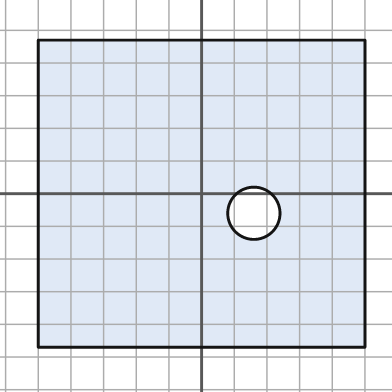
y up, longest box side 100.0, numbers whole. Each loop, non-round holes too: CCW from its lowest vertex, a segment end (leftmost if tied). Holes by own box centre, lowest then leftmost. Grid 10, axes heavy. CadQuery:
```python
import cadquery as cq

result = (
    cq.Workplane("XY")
    .moveTo(-50.0, -47.0)
    .lineTo(50.0, -47.0)
    .lineTo(50.0, 47.0)
    .lineTo(-50.0, 47.0)
    .close()
    .moveTo(16.0, -6.0)
    .circle(8.0)
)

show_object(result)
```